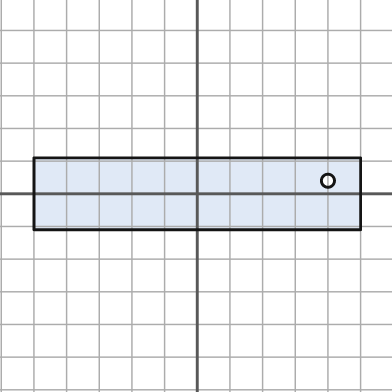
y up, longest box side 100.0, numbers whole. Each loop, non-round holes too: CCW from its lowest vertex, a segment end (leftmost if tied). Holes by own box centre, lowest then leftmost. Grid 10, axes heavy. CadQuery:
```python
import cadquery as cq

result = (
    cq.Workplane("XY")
    .moveTo(-50.0, -11.0)
    .lineTo(50.0, -11.0)
    .lineTo(50.0, 11.0)
    .lineTo(-50.0, 11.0)
    .close()
    .moveTo(40.0, 4.0)
    .circle(2.0)
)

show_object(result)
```